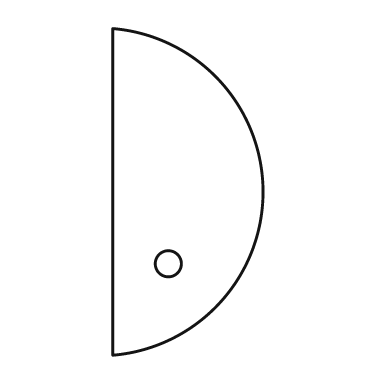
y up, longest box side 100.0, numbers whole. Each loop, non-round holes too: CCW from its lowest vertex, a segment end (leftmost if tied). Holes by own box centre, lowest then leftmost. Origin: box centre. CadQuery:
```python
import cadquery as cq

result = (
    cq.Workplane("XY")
    .moveTo(-23.0, -50.0)
    .threePointArc((23.0, 0.0), (-23.0, 50.0))
    .close()
    .moveTo(-6.0, -22.0)
    .circle(4.0)
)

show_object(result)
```